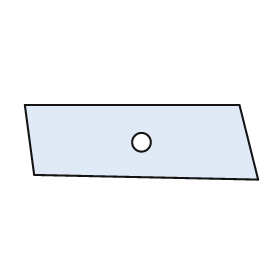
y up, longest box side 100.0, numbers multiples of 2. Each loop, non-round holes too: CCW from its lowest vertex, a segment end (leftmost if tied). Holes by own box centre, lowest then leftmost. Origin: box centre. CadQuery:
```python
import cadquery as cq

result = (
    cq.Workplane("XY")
    .moveTo(50.0, -16.0)
    .lineTo(42.0, 16.0)
    .lineTo(-50.0, 16.0)
    .lineTo(-46.0, -14.0)
    .close()
    .moveTo(0.0, 0.0)
    .circle(4.0)
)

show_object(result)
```